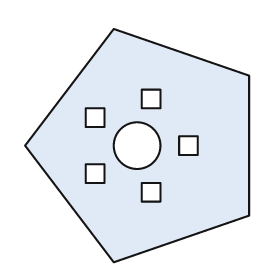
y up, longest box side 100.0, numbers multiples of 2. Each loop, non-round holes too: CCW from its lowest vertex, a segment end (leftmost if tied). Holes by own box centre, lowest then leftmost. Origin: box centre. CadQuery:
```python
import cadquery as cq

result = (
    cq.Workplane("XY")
    .moveTo(-10.0, -50.0)
    .lineTo(48.0, -30.0)
    .lineTo(48.0, 30.0)
    .lineTo(-10.0, 50.0)
    .lineTo(-48.0, 0.0)
    .close()
    .moveTo(2.0, -24.0)
    .lineTo(10.0, -24.0)
    .lineTo(10.0, -16.0)
    .lineTo(2.0, -16.0)
    .close()
    .moveTo(-22.0, -16.0)
    .lineTo(-14.0, -16.0)
    .lineTo(-14.0, -8.0)
    .lineTo(-22.0, -8.0)
    .close()
    .moveTo(0.0, 0.0)
    .circle(10.0)
    .moveTo(18.0, -4.0)
    .lineTo(26.0, -4.0)
    .lineTo(26.0, 4.0)
    .lineTo(18.0, 4.0)
    .close()
    .moveTo(-22.0, 8.0)
    .lineTo(-14.0, 8.0)
    .lineTo(-14.0, 16.0)
    .lineTo(-22.0, 16.0)
    .close()
    .moveTo(2.0, 16.0)
    .lineTo(10.0, 16.0)
    .lineTo(10.0, 24.0)
    .lineTo(2.0, 24.0)
    .close()
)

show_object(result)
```